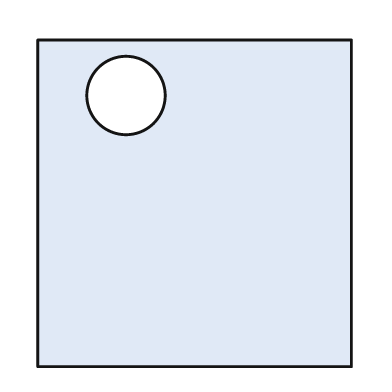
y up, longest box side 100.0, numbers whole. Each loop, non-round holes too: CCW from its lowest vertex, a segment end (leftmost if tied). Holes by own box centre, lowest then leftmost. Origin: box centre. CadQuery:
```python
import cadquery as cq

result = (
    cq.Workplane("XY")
    .moveTo(-48.0, -50.0)
    .lineTo(48.0, -50.0)
    .lineTo(48.0, 50.0)
    .lineTo(-48.0, 50.0)
    .close()
    .moveTo(-21.0, 33.0)
    .circle(12.0)
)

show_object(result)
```